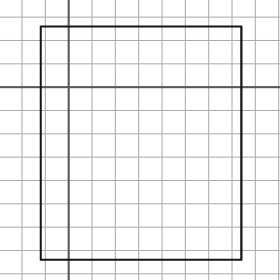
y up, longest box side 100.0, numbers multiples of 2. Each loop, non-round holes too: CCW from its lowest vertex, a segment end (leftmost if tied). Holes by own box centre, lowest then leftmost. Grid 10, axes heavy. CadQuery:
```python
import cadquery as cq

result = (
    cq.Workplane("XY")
    .moveTo(-12.0, -74.0)
    .lineTo(74.0, -74.0)
    .lineTo(74.0, 26.0)
    .lineTo(-12.0, 26.0)
    .close()
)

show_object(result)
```